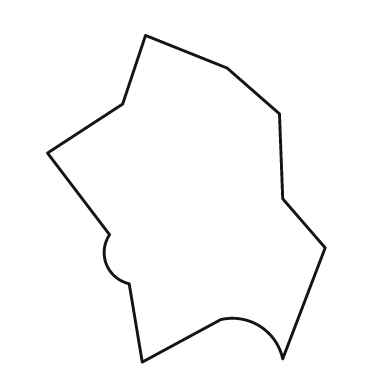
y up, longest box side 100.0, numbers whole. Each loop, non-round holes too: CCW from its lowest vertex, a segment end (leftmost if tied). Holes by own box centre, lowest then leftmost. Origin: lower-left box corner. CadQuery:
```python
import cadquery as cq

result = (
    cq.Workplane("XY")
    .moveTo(29.0, 0.0)
    .lineTo(53.0, 13.0)
    .threePointArc((65.0, 11.0), (72.0, 1.0))
    .lineTo(85.0, 35.0)
    .lineTo(72.0, 50.0)
    .lineTo(71.0, 76.0)
    .lineTo(55.0, 90.0)
    .lineTo(30.0, 100.0)
    .lineTo(23.0, 79.0)
    .lineTo(0.0, 64.0)
    .lineTo(19.0, 39.0)
    .threePointArc((18.0, 30.0), (25.0, 24.0))
    .close()
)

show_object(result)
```